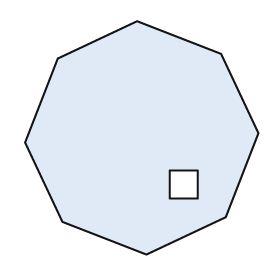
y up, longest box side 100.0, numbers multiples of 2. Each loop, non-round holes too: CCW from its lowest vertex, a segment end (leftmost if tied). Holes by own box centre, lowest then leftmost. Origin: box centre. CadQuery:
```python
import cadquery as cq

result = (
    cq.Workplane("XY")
    .moveTo(2.0, -50.0)
    .lineTo(36.0, -34.0)
    .lineTo(50.0, 2.0)
    .lineTo(34.0, 36.0)
    .lineTo(-2.0, 50.0)
    .lineTo(-36.0, 34.0)
    .lineTo(-50.0, -2.0)
    .lineTo(-34.0, -36.0)
    .close()
    .moveTo(12.0, -26.0)
    .lineTo(24.0, -26.0)
    .lineTo(24.0, -14.0)
    .lineTo(12.0, -14.0)
    .close()
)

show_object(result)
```